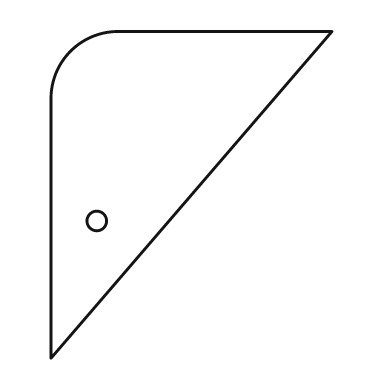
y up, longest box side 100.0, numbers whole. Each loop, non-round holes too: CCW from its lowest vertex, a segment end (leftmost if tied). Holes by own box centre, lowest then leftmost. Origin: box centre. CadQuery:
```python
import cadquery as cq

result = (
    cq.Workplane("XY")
    .moveTo(-43.0, -50.0)
    .lineTo(43.0, 50.0)
    .lineTo(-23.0, 50.0)
    .threePointArc((-37.0, 44.0), (-43.0, 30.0))
    .close()
    .moveTo(-29.0, -8.0)
    .circle(3.0)
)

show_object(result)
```